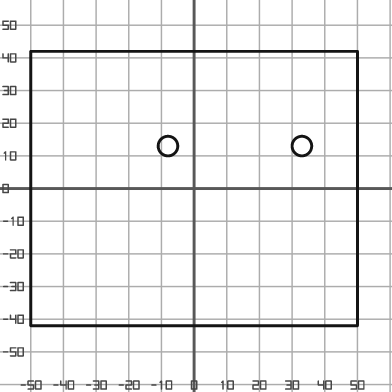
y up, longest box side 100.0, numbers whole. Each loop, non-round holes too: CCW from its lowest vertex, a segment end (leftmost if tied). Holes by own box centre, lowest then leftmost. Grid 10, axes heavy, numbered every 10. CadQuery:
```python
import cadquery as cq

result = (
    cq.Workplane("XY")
    .moveTo(-50.0, -42.0)
    .lineTo(50.0, -42.0)
    .lineTo(50.0, 42.0)
    .lineTo(-50.0, 42.0)
    .close()
    .moveTo(-8.0, 13.0)
    .circle(3.0)
    .moveTo(33.0, 13.0)
    .circle(3.0)
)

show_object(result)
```